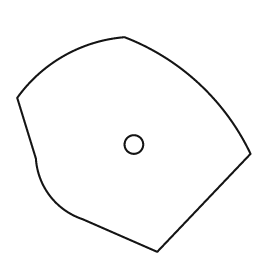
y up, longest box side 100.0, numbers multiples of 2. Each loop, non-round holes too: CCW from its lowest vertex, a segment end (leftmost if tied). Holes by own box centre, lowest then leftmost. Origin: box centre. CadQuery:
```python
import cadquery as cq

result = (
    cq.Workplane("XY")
    .moveTo(10.0, -46.0)
    .lineTo(50.0, -4.0)
    .threePointArc((28.0, 26.0), (-4.0, 46.0))
    .threePointArc((-30.0, 38.0), (-50.0, 20.0))
    .lineTo(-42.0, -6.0)
    .threePointArc((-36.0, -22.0), (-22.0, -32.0))
    .close()
    .moveTo(0.0, 0.0)
    .circle(4.0)
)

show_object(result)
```